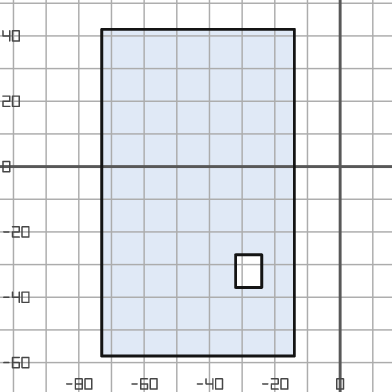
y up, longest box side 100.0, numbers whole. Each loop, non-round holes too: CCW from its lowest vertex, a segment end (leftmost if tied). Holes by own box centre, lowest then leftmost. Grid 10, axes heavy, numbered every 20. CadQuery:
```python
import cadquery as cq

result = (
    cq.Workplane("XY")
    .moveTo(-73.0, -58.0)
    .lineTo(-14.0, -58.0)
    .lineTo(-14.0, 42.0)
    .lineTo(-73.0, 42.0)
    .close()
    .moveTo(-32.0, -37.0)
    .lineTo(-24.0, -37.0)
    .lineTo(-24.0, -27.0)
    .lineTo(-32.0, -27.0)
    .close()
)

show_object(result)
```